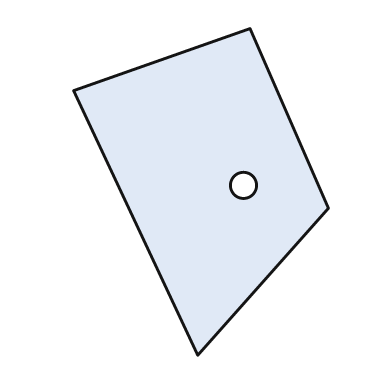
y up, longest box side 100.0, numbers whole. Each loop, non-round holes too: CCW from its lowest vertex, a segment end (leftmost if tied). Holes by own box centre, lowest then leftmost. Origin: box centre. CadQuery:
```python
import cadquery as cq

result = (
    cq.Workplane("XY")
    .moveTo(-1.0, -50.0)
    .lineTo(39.0, -5.0)
    .lineTo(15.0, 50.0)
    .lineTo(-39.0, 31.0)
    .close()
    .moveTo(13.0, 2.0)
    .circle(4.0)
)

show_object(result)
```